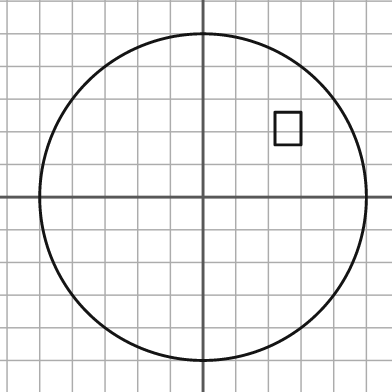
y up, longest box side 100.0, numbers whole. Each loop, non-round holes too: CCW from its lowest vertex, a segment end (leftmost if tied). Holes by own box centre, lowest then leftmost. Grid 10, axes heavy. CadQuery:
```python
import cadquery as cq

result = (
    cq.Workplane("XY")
    .moveTo(0.0, 0.0)
    .circle(50.0)
    .moveTo(22.0, 16.0)
    .lineTo(30.0, 16.0)
    .lineTo(30.0, 26.0)
    .lineTo(22.0, 26.0)
    .close()
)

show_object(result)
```